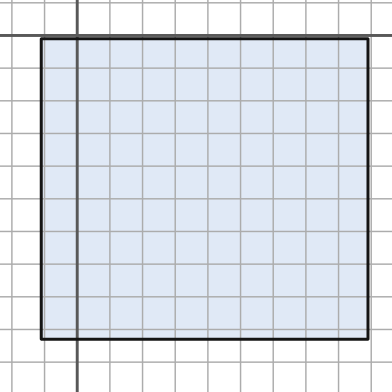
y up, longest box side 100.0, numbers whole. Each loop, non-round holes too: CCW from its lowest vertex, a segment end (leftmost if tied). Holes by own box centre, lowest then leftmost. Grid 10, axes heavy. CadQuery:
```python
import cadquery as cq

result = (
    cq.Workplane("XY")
    .moveTo(-11.0, -93.0)
    .lineTo(89.0, -93.0)
    .lineTo(89.0, -1.0)
    .lineTo(-11.0, -1.0)
    .close()
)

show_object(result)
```